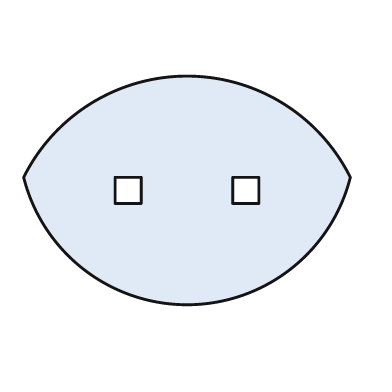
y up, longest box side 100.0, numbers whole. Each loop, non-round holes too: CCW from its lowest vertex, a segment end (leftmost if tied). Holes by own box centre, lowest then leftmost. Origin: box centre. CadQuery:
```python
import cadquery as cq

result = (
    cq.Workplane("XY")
    .moveTo(-50.0, 4.0)
    .threePointArc((0.0, -35.0), (50.0, 4.0))
    .threePointArc((0.0, 35.0), (-50.0, 4.0))
    .close()
    .moveTo(-22.0, -4.0)
    .lineTo(-14.0, -4.0)
    .lineTo(-14.0, 4.0)
    .lineTo(-22.0, 4.0)
    .close()
    .moveTo(14.0, -4.0)
    .lineTo(22.0, -4.0)
    .lineTo(22.0, 4.0)
    .lineTo(14.0, 4.0)
    .close()
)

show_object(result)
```